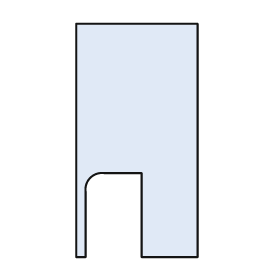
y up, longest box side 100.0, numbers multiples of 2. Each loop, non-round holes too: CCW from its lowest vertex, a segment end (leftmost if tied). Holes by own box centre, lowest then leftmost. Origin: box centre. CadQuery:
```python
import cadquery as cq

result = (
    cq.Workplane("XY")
    .moveTo(-26.0, -50.0)
    .lineTo(-22.0, -50.0)
    .lineTo(-22.0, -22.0)
    .threePointArc((-20.0, -16.0), (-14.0, -14.0))
    .lineTo(2.0, -14.0)
    .lineTo(2.0, -50.0)
    .lineTo(26.0, -50.0)
    .lineTo(26.0, 50.0)
    .lineTo(-26.0, 50.0)
    .close()
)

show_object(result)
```